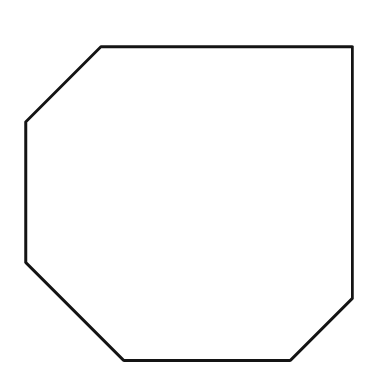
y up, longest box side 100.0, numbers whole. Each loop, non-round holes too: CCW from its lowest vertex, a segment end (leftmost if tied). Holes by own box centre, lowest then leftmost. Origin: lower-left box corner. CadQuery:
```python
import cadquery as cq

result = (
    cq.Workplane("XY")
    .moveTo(30.0, 0.0)
    .lineTo(81.0, 0.0)
    .lineTo(100.0, 19.0)
    .lineTo(100.0, 96.0)
    .lineTo(23.0, 96.0)
    .lineTo(0.0, 73.0)
    .lineTo(0.0, 30.0)
    .close()
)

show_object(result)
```